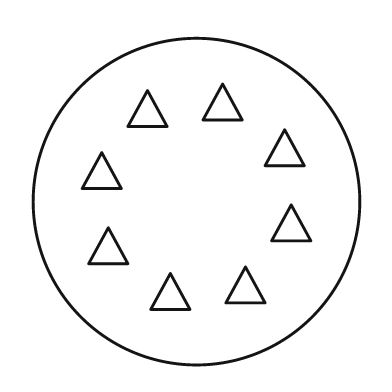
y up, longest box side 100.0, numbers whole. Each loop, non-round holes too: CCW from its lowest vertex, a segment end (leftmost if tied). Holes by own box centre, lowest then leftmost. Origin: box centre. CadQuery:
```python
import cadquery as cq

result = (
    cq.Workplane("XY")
    .moveTo(0.0, 0.0)
    .circle(50.0)
    .moveTo(-14.0, -33.0)
    .lineTo(-2.0, -33.0)
    .lineTo(-8.0, -22.0)
    .close()
    .moveTo(9.0, -31.0)
    .lineTo(21.0, -31.0)
    .lineTo(15.0, -20.0)
    .close()
    .moveTo(-33.0, -19.0)
    .lineTo(-21.0, -19.0)
    .lineTo(-27.0, -8.0)
    .close()
    .moveTo(23.0, -12.0)
    .lineTo(35.0, -12.0)
    .lineTo(29.0, -1.0)
    .close()
    .moveTo(-35.0, 4.0)
    .lineTo(-23.0, 4.0)
    .lineTo(-29.0, 15.0)
    .close()
    .moveTo(21.0, 11.0)
    .lineTo(33.0, 11.0)
    .lineTo(27.0, 22.0)
    .close()
    .moveTo(-21.0, 23.0)
    .lineTo(-9.0, 23.0)
    .lineTo(-15.0, 34.0)
    .close()
    .moveTo(2.0, 25.0)
    .lineTo(14.0, 25.0)
    .lineTo(8.0, 36.0)
    .close()
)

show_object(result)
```